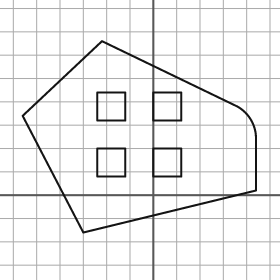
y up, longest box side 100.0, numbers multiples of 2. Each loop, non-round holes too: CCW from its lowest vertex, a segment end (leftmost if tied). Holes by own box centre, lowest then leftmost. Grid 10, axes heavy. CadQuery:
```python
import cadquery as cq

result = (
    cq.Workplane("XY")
    .moveTo(-30.0, -16.0)
    .lineTo(44.0, 2.0)
    .lineTo(44.0, 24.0)
    .threePointArc((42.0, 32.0), (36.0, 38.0))
    .lineTo(-22.0, 66.0)
    .lineTo(-56.0, 34.0)
    .close()
    .moveTo(-24.0, 8.0)
    .lineTo(-12.0, 8.0)
    .lineTo(-12.0, 20.0)
    .lineTo(-24.0, 20.0)
    .close()
    .moveTo(0.0, 8.0)
    .lineTo(12.0, 8.0)
    .lineTo(12.0, 20.0)
    .lineTo(0.0, 20.0)
    .close()
    .moveTo(-24.0, 32.0)
    .lineTo(-12.0, 32.0)
    .lineTo(-12.0, 44.0)
    .lineTo(-24.0, 44.0)
    .close()
    .moveTo(0.0, 32.0)
    .lineTo(12.0, 32.0)
    .lineTo(12.0, 44.0)
    .lineTo(0.0, 44.0)
    .close()
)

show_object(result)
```